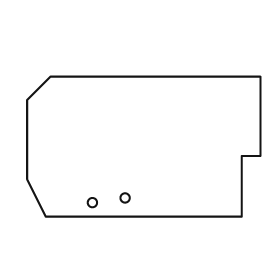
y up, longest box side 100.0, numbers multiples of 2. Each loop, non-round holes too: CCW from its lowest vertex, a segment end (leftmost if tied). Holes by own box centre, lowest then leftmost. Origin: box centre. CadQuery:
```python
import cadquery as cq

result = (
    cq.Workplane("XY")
    .moveTo(-42.0, -30.0)
    .lineTo(42.0, -30.0)
    .lineTo(42.0, -4.0)
    .lineTo(50.0, -4.0)
    .lineTo(50.0, 30.0)
    .lineTo(-40.0, 30.0)
    .lineTo(-50.0, 20.0)
    .lineTo(-50.0, -14.0)
    .close()
    .moveTo(-22.0, -24.0)
    .circle(2.0)
    .moveTo(-8.0, -22.0)
    .circle(2.0)
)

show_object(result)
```